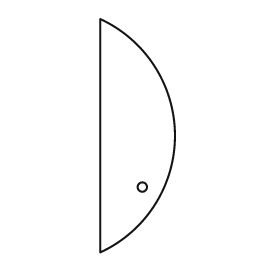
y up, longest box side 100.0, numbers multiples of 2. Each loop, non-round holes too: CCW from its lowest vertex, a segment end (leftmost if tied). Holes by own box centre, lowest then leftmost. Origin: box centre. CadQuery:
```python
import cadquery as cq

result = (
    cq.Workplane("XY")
    .moveTo(-16.0, -50.0)
    .threePointArc((16.0, 0.0), (-16.0, 50.0))
    .close()
    .moveTo(2.0, -22.0)
    .circle(2.0)
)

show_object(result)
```